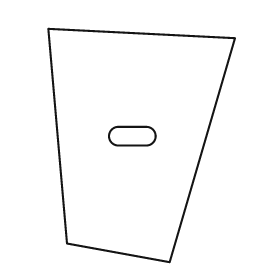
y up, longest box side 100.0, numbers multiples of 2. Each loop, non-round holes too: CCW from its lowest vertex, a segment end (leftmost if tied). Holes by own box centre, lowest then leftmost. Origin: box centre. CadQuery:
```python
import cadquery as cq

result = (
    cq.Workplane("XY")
    .moveTo(12.0, -50.0)
    .lineTo(40.0, 46.0)
    .lineTo(-40.0, 50.0)
    .lineTo(-32.0, -42.0)
    .close()
    .moveTo(-10.0, 0.0)
    .lineTo(2.0, 0.0)
    .threePointArc((6.0, 4.0), (2.0, 8.0))
    .lineTo(-10.0, 8.0)
    .threePointArc((-14.0, 4.0), (-10.0, 0.0))
    .close()
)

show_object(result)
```